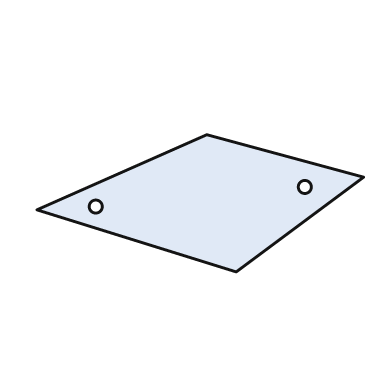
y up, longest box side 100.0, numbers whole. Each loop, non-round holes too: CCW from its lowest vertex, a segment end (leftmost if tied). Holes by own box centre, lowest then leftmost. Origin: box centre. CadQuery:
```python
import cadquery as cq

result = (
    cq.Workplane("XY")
    .moveTo(11.0, -21.0)
    .lineTo(50.0, 8.0)
    .lineTo(2.0, 21.0)
    .lineTo(-50.0, -2.0)
    .close()
    .moveTo(-32.0, -1.0)
    .circle(2.0)
    .moveTo(32.0, 5.0)
    .circle(2.0)
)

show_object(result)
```